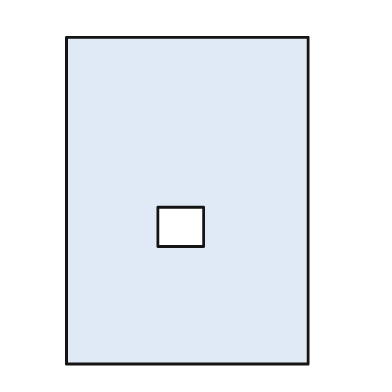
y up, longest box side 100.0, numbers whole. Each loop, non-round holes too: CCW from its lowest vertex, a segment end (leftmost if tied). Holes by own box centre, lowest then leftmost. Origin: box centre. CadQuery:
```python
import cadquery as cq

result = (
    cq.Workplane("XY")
    .moveTo(-37.0, -50.0)
    .lineTo(37.0, -50.0)
    .lineTo(37.0, 50.0)
    .lineTo(-37.0, 50.0)
    .close()
    .moveTo(-9.0, -14.0)
    .lineTo(5.0, -14.0)
    .lineTo(5.0, -2.0)
    .lineTo(-9.0, -2.0)
    .close()
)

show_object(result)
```